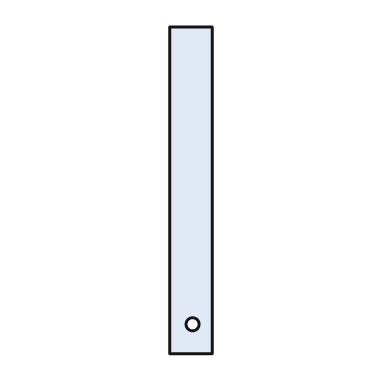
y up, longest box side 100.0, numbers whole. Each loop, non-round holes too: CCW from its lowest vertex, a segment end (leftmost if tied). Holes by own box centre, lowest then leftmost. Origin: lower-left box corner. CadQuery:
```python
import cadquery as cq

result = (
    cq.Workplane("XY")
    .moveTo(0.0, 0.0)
    .lineTo(13.0, 0.0)
    .lineTo(13.0, 100.0)
    .lineTo(0.0, 100.0)
    .close()
    .moveTo(7.0, 9.0)
    .circle(2.0)
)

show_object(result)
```